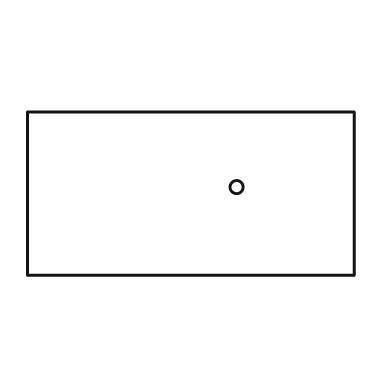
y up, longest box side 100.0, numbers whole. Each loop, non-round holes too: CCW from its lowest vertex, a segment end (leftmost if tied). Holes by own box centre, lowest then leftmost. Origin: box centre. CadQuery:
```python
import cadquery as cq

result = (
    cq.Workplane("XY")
    .moveTo(-50.0, -25.0)
    .lineTo(50.0, -25.0)
    .lineTo(50.0, 25.0)
    .lineTo(-50.0, 25.0)
    .close()
    .moveTo(14.0, 2.0)
    .circle(2.0)
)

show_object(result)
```